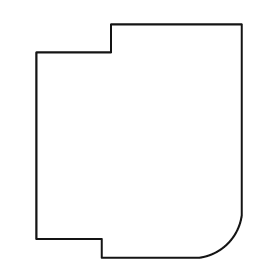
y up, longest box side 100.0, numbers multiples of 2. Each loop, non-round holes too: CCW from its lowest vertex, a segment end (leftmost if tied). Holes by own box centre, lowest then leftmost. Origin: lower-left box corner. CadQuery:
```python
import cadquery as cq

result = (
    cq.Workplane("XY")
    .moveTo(28.0, 0.0)
    .lineTo(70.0, 0.0)
    .threePointArc((82.0, 6.0), (88.0, 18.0))
    .lineTo(88.0, 100.0)
    .lineTo(32.0, 100.0)
    .lineTo(32.0, 88.0)
    .lineTo(0.0, 88.0)
    .lineTo(0.0, 8.0)
    .lineTo(28.0, 8.0)
    .close()
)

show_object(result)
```